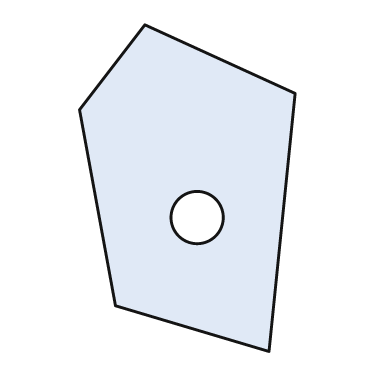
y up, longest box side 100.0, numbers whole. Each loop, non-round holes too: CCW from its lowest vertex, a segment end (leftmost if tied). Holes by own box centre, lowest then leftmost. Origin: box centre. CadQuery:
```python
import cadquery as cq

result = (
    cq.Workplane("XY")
    .moveTo(25.0, -50.0)
    .lineTo(33.0, 29.0)
    .lineTo(-13.0, 50.0)
    .lineTo(-33.0, 24.0)
    .lineTo(-22.0, -36.0)
    .close()
    .moveTo(3.0, -9.0)
    .circle(8.0)
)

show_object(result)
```